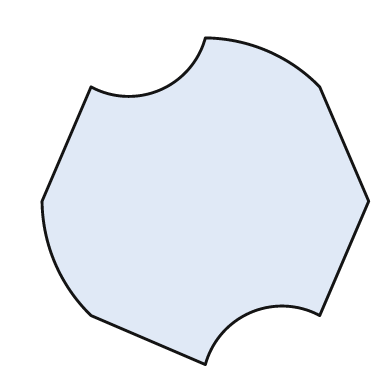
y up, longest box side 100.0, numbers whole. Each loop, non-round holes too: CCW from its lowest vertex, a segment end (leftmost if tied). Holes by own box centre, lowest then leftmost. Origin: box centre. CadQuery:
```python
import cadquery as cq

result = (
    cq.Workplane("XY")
    .moveTo(0.0, -50.0)
    .threePointArc((14.0, -34.0), (35.0, -35.0))
    .lineTo(50.0, 0.0)
    .lineTo(35.0, 35.0)
    .threePointArc((19.0, 46.0), (0.0, 50.0))
    .threePointArc((-14.0, 34.0), (-35.0, 35.0))
    .lineTo(-50.0, 0.0)
    .threePointArc((-46.0, -19.0), (-35.0, -35.0))
    .close()
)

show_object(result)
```